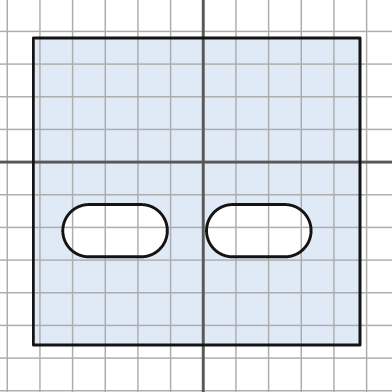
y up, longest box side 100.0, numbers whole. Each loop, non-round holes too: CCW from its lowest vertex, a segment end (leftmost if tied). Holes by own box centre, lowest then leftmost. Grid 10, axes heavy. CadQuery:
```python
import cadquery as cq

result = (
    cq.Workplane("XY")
    .moveTo(-52.0, -56.0)
    .lineTo(48.0, -56.0)
    .lineTo(48.0, 38.0)
    .lineTo(-52.0, 38.0)
    .close()
    .moveTo(-35.0, -29.0)
    .lineTo(-19.0, -29.0)
    .threePointArc((-11.0, -21.0), (-19.0, -13.0))
    .lineTo(-35.0, -13.0)
    .threePointArc((-43.0, -21.0), (-35.0, -29.0))
    .close()
    .moveTo(9.0, -29.0)
    .lineTo(25.0, -29.0)
    .threePointArc((33.0, -21.0), (25.0, -13.0))
    .lineTo(9.0, -13.0)
    .threePointArc((1.0, -21.0), (9.0, -29.0))
    .close()
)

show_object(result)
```